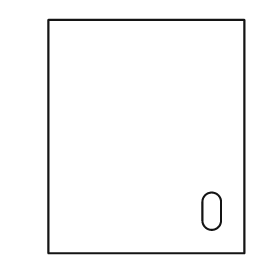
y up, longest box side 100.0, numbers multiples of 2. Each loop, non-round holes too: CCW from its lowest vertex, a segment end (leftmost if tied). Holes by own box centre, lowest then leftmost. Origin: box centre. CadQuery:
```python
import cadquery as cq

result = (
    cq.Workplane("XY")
    .moveTo(-42.0, -50.0)
    .lineTo(42.0, -50.0)
    .lineTo(42.0, 50.0)
    .lineTo(-42.0, 50.0)
    .close()
    .moveTo(24.0, -36.0)
    .threePointArc((28.0, -40.0), (32.0, -36.0))
    .lineTo(32.0, -28.0)
    .threePointArc((28.0, -24.0), (24.0, -28.0))
    .close()
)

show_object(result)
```